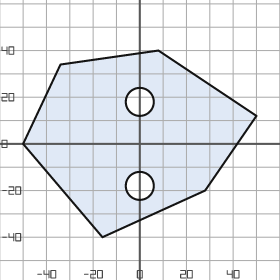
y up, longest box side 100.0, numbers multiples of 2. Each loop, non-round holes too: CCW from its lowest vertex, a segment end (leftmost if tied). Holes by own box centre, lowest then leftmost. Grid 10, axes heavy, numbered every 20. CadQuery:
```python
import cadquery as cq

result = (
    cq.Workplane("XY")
    .moveTo(-16.0, -40.0)
    .lineTo(28.0, -20.0)
    .lineTo(50.0, 12.0)
    .lineTo(8.0, 40.0)
    .lineTo(-34.0, 34.0)
    .lineTo(-50.0, 0.0)
    .close()
    .moveTo(0.0, -18.0)
    .circle(6.0)
    .moveTo(0.0, 18.0)
    .circle(6.0)
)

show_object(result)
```